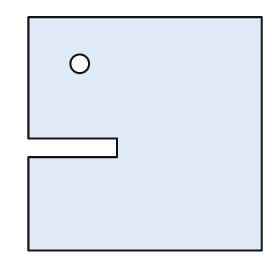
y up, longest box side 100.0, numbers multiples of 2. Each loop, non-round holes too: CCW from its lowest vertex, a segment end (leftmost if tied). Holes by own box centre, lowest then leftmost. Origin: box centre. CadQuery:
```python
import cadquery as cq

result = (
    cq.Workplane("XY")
    .moveTo(-50.0, -50.0)
    .lineTo(50.0, -50.0)
    .lineTo(50.0, 50.0)
    .lineTo(-50.0, 50.0)
    .lineTo(-50.0, -2.0)
    .lineTo(-12.0, -2.0)
    .lineTo(-12.0, -10.0)
    .lineTo(-50.0, -10.0)
    .close()
    .moveTo(-28.0, 30.0)
    .circle(4.0)
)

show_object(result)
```